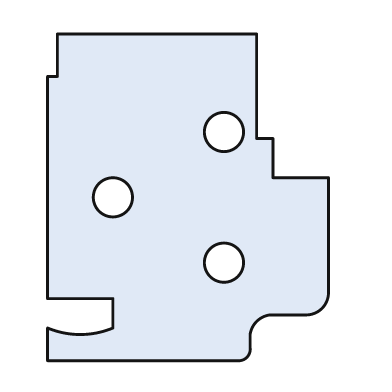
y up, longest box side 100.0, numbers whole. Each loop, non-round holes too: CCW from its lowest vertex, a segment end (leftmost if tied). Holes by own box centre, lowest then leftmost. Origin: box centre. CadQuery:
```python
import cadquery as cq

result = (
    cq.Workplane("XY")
    .moveTo(-43.0, -50.0)
    .lineTo(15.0, -50.0)
    .threePointArc((18.0, -49.0), (19.0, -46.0))
    .lineTo(19.0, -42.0)
    .threePointArc((21.0, -38.0), (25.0, -36.0))
    .lineTo(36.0, -36.0)
    .threePointArc((41.0, -34.0), (43.0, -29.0))
    .lineTo(43.0, 6.0)
    .lineTo(26.0, 6.0)
    .lineTo(26.0, 18.0)
    .lineTo(21.0, 18.0)
    .lineTo(21.0, 50.0)
    .lineTo(-40.0, 50.0)
    .lineTo(-40.0, 37.0)
    .lineTo(-43.0, 37.0)
    .lineTo(-43.0, -31.0)
    .lineTo(-23.0, -31.0)
    .lineTo(-23.0, -40.0)
    .threePointArc((-33.0, -42.0), (-43.0, -40.0))
    .close()
    .moveTo(11.0, -20.0)
    .circle(6.0)
    .moveTo(-23.0, 0.0)
    .circle(6.0)
    .moveTo(11.0, 20.0)
    .circle(6.0)
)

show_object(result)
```